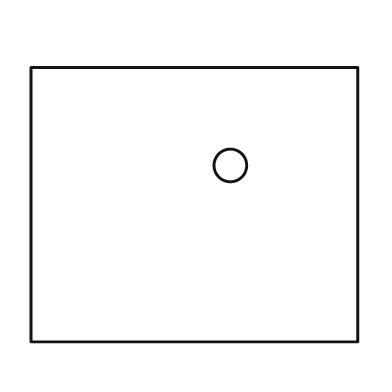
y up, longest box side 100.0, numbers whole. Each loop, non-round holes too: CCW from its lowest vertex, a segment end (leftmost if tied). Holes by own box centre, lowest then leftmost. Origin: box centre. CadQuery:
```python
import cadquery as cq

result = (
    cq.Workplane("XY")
    .moveTo(-50.0, -42.0)
    .lineTo(50.0, -42.0)
    .lineTo(50.0, 42.0)
    .lineTo(-50.0, 42.0)
    .close()
    .moveTo(11.0, 12.0)
    .circle(5.0)
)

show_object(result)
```